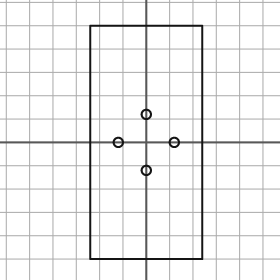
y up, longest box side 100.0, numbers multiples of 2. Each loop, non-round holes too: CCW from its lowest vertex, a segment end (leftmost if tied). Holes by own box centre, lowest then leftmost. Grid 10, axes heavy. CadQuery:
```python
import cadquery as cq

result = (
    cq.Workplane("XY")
    .moveTo(-24.0, -50.0)
    .lineTo(24.0, -50.0)
    .lineTo(24.0, 50.0)
    .lineTo(-24.0, 50.0)
    .close()
    .moveTo(0.0, -12.0)
    .circle(2.0)
    .moveTo(-12.0, 0.0)
    .circle(2.0)
    .moveTo(12.0, 0.0)
    .circle(2.0)
    .moveTo(0.0, 12.0)
    .circle(2.0)
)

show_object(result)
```